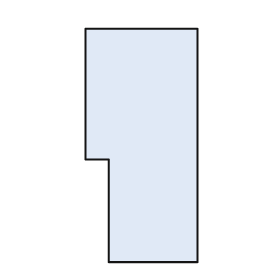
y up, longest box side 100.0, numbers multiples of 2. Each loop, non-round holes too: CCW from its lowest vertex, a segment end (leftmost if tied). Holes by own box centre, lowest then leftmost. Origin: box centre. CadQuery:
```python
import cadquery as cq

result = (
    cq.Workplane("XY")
    .moveTo(-14.0, -50.0)
    .lineTo(24.0, -50.0)
    .lineTo(24.0, 50.0)
    .lineTo(-24.0, 50.0)
    .lineTo(-24.0, -6.0)
    .lineTo(-14.0, -6.0)
    .close()
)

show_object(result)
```